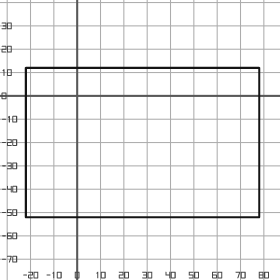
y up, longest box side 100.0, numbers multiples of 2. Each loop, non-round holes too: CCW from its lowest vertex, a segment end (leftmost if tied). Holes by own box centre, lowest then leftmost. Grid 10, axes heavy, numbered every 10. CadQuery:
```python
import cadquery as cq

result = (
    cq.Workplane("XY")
    .moveTo(-22.0, -52.0)
    .lineTo(78.0, -52.0)
    .lineTo(78.0, 12.0)
    .lineTo(-22.0, 12.0)
    .close()
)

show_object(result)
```